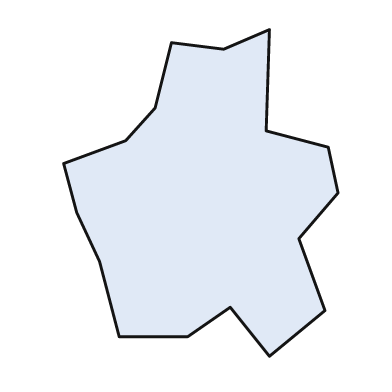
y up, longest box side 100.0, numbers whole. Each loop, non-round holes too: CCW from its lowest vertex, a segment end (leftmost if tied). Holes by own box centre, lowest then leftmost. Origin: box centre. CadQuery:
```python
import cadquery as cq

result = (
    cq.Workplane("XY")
    .moveTo(21.0, -50.0)
    .lineTo(38.0, -36.0)
    .lineTo(30.0, -14.0)
    .lineTo(42.0, 0.0)
    .lineTo(39.0, 14.0)
    .lineTo(20.0, 19.0)
    .lineTo(21.0, 50.0)
    .lineTo(7.0, 44.0)
    .lineTo(-9.0, 46.0)
    .lineTo(-14.0, 26.0)
    .lineTo(-23.0, 16.0)
    .lineTo(-42.0, 9.0)
    .lineTo(-38.0, -6.0)
    .lineTo(-31.0, -21.0)
    .lineTo(-25.0, -44.0)
    .lineTo(-4.0, -44.0)
    .lineTo(9.0, -35.0)
    .close()
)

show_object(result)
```